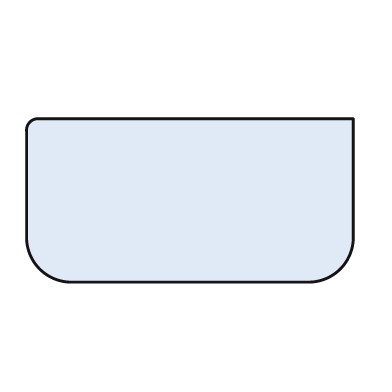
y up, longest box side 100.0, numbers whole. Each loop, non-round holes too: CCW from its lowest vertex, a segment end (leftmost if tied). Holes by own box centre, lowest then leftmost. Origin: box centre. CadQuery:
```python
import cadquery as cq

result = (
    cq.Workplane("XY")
    .moveTo(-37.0, -25.0)
    .lineTo(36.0, -25.0)
    .threePointArc((46.0, -21.0), (50.0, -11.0))
    .lineTo(50.0, 25.0)
    .lineTo(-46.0, 25.0)
    .threePointArc((-49.0, 24.0), (-50.0, 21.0))
    .lineTo(-50.0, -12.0)
    .threePointArc((-46.0, -21.0), (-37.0, -25.0))
    .close()
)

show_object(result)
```